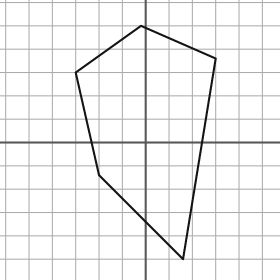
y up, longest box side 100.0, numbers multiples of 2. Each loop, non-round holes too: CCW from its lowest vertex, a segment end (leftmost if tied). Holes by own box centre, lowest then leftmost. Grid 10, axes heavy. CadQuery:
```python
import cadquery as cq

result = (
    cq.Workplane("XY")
    .moveTo(16.0, -50.0)
    .lineTo(30.0, 36.0)
    .lineTo(-2.0, 50.0)
    .lineTo(-30.0, 30.0)
    .lineTo(-20.0, -14.0)
    .close()
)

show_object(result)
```